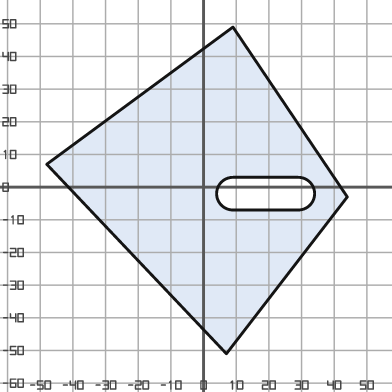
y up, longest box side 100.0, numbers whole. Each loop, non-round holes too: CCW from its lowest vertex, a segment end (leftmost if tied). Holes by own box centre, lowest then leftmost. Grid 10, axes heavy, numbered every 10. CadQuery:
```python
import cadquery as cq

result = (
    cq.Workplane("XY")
    .moveTo(7.0, -51.0)
    .lineTo(44.0, -3.0)
    .lineTo(9.0, 49.0)
    .lineTo(-48.0, 7.0)
    .close()
    .moveTo(9.0, -7.0)
    .lineTo(29.0, -7.0)
    .threePointArc((34.0, -2.0), (29.0, 3.0))
    .lineTo(9.0, 3.0)
    .threePointArc((4.0, -2.0), (9.0, -7.0))
    .close()
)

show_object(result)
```